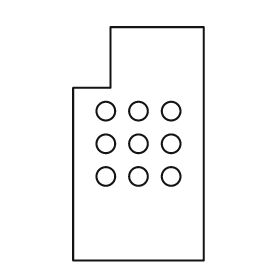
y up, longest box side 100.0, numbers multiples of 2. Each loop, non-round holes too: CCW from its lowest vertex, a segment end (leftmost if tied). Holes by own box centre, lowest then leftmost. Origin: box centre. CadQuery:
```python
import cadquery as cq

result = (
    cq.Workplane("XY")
    .moveTo(-28.0, -50.0)
    .lineTo(28.0, -50.0)
    .lineTo(28.0, 50.0)
    .lineTo(-12.0, 50.0)
    .lineTo(-12.0, 24.0)
    .lineTo(-28.0, 24.0)
    .close()
    .moveTo(-14.0, -14.0)
    .circle(4.0)
    .moveTo(0.0, -14.0)
    .circle(4.0)
    .moveTo(14.0, -14.0)
    .circle(4.0)
    .moveTo(-14.0, 0.0)
    .circle(4.0)
    .moveTo(0.0, 0.0)
    .circle(4.0)
    .moveTo(14.0, 0.0)
    .circle(4.0)
    .moveTo(-14.0, 14.0)
    .circle(4.0)
    .moveTo(0.0, 14.0)
    .circle(4.0)
    .moveTo(14.0, 14.0)
    .circle(4.0)
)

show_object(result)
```